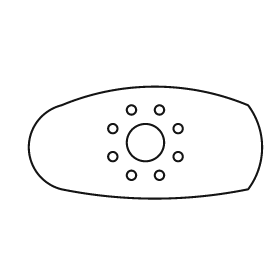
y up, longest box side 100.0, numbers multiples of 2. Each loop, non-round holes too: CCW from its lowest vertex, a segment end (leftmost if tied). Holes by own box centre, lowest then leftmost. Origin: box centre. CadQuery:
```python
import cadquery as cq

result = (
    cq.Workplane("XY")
    .moveTo(-36.0, -20.0)
    .threePointArc((4.0, -24.0), (44.0, -20.0))
    .threePointArc((50.0, -2.0), (44.0, 16.0))
    .threePointArc((4.0, 24.0), (-36.0, 16.0))
    .threePointArc((-50.0, -2.0), (-36.0, -20.0))
    .close()
    .moveTo(-6.0, -14.0)
    .circle(2.0)
    .moveTo(6.0, -14.0)
    .circle(2.0)
    .moveTo(-14.0, -6.0)
    .circle(2.0)
    .moveTo(14.0, -6.0)
    .circle(2.0)
    .moveTo(0.0, 0.0)
    .circle(8.0)
    .moveTo(-14.0, 6.0)
    .circle(2.0)
    .moveTo(14.0, 6.0)
    .circle(2.0)
    .moveTo(-6.0, 14.0)
    .circle(2.0)
    .moveTo(6.0, 14.0)
    .circle(2.0)
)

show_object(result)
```